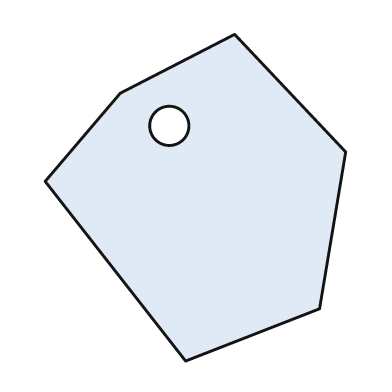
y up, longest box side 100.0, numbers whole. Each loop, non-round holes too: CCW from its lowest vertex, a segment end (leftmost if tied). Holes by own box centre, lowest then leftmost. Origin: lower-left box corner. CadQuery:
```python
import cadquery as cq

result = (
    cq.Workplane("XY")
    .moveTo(43.0, 0.0)
    .lineTo(84.0, 16.0)
    .lineTo(92.0, 64.0)
    .lineTo(58.0, 100.0)
    .lineTo(23.0, 82.0)
    .lineTo(0.0, 55.0)
    .close()
    .moveTo(38.0, 72.0)
    .circle(6.0)
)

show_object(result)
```